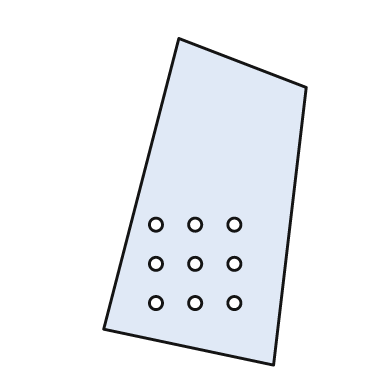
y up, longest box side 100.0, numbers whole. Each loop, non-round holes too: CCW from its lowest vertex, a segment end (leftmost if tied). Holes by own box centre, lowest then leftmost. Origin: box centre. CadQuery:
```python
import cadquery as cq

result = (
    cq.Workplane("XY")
    .moveTo(21.0, -50.0)
    .lineTo(31.0, 35.0)
    .lineTo(-8.0, 50.0)
    .lineTo(-31.0, -39.0)
    .close()
    .moveTo(-15.0, -31.0)
    .circle(2.0)
    .moveTo(-3.0, -31.0)
    .circle(2.0)
    .moveTo(9.0, -31.0)
    .circle(2.0)
    .moveTo(-15.0, -19.0)
    .circle(2.0)
    .moveTo(-3.0, -19.0)
    .circle(2.0)
    .moveTo(9.0, -19.0)
    .circle(2.0)
    .moveTo(-15.0, -7.0)
    .circle(2.0)
    .moveTo(-3.0, -7.0)
    .circle(2.0)
    .moveTo(9.0, -7.0)
    .circle(2.0)
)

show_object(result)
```